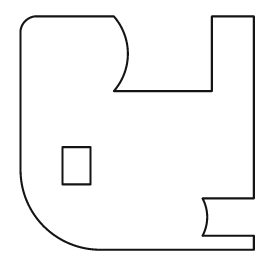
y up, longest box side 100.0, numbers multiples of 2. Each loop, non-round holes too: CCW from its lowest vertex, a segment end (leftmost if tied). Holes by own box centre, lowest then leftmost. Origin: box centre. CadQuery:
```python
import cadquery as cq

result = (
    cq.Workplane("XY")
    .moveTo(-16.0, -50.0)
    .lineTo(50.0, -50.0)
    .lineTo(50.0, -44.0)
    .lineTo(28.0, -44.0)
    .threePointArc((30.0, -36.0), (28.0, -28.0))
    .lineTo(50.0, -28.0)
    .lineTo(50.0, 50.0)
    .lineTo(32.0, 50.0)
    .lineTo(32.0, 18.0)
    .lineTo(-10.0, 18.0)
    .threePointArc((-4.0, 34.0), (-10.0, 50.0))
    .lineTo(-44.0, 50.0)
    .threePointArc((-48.0, 48.0), (-50.0, 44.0))
    .lineTo(-50.0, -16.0)
    .threePointArc((-40.0, -40.0), (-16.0, -50.0))
    .close()
    .moveTo(-32.0, -22.0)
    .lineTo(-20.0, -22.0)
    .lineTo(-20.0, -6.0)
    .lineTo(-32.0, -6.0)
    .close()
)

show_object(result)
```